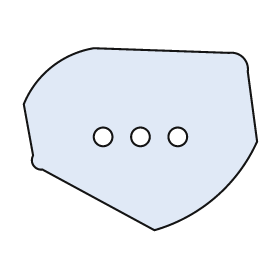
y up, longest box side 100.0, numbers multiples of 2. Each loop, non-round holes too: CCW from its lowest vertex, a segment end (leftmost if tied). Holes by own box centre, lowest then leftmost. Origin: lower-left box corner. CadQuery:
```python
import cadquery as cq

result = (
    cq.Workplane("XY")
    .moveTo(56.0, 0.0)
    .threePointArc((82.0, 14.0), (100.0, 38.0))
    .lineTo(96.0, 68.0)
    .threePointArc((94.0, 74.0), (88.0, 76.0))
    .lineTo(30.0, 78.0)
    .threePointArc((12.0, 70.0), (0.0, 54.0))
    .lineTo(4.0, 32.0)
    .threePointArc((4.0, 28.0), (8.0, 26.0))
    .close()
    .moveTo(34.0, 40.0)
    .circle(4.0)
    .moveTo(50.0, 40.0)
    .circle(4.0)
    .moveTo(66.0, 40.0)
    .circle(4.0)
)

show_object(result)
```